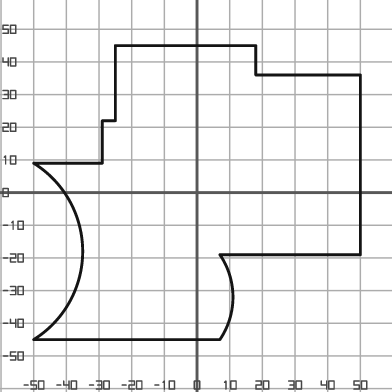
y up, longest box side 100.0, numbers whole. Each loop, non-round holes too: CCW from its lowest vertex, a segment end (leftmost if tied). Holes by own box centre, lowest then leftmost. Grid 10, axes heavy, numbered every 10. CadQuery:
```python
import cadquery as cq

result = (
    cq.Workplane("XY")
    .moveTo(-50.0, -45.0)
    .lineTo(7.0, -45.0)
    .threePointArc((11.0, -32.0), (7.0, -19.0))
    .lineTo(50.0, -19.0)
    .lineTo(50.0, 36.0)
    .lineTo(18.0, 36.0)
    .lineTo(18.0, 45.0)
    .lineTo(-25.0, 45.0)
    .lineTo(-25.0, 22.0)
    .lineTo(-29.0, 22.0)
    .lineTo(-29.0, 9.0)
    .lineTo(-50.0, 9.0)
    .threePointArc((-35.0, -18.0), (-50.0, -45.0))
    .close()
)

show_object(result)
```